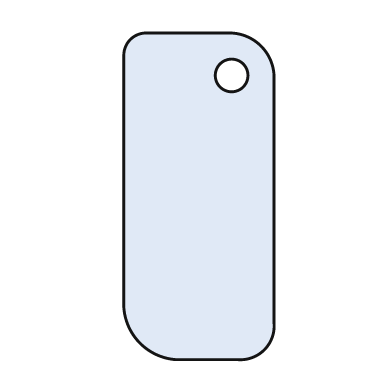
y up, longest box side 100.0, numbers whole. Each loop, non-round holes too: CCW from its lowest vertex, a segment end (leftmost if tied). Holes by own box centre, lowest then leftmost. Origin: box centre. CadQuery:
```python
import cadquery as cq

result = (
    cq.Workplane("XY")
    .moveTo(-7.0, -50.0)
    .lineTo(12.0, -50.0)
    .threePointArc((20.0, -47.0), (23.0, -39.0))
    .lineTo(23.0, 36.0)
    .threePointArc((19.0, 46.0), (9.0, 50.0))
    .lineTo(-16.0, 50.0)
    .threePointArc((-21.0, 48.0), (-23.0, 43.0))
    .lineTo(-23.0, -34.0)
    .threePointArc((-18.0, -45.0), (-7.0, -50.0))
    .close()
    .moveTo(10.0, 37.0)
    .circle(5.0)
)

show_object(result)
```